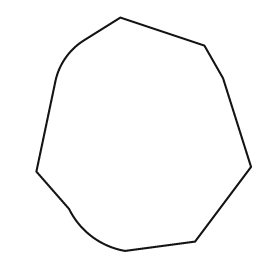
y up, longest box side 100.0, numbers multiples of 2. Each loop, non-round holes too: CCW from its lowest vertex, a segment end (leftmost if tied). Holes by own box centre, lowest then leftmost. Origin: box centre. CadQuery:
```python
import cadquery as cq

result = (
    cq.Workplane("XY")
    .moveTo(-8.0, -50.0)
    .lineTo(22.0, -46.0)
    .lineTo(46.0, -14.0)
    .lineTo(34.0, 24.0)
    .lineTo(26.0, 38.0)
    .lineTo(-10.0, 50.0)
    .lineTo(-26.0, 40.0)
    .threePointArc((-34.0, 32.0), (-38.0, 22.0))
    .lineTo(-46.0, -16.0)
    .lineTo(-32.0, -32.0)
    .threePointArc((-22.0, -44.0), (-8.0, -50.0))
    .close()
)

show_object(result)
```